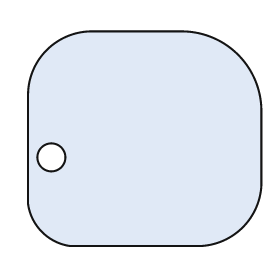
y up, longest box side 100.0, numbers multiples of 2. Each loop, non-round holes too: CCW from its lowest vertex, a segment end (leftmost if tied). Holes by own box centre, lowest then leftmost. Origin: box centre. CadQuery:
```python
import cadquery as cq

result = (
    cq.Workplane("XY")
    .moveTo(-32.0, -46.0)
    .lineTo(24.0, -46.0)
    .threePointArc((42.0, -38.0), (50.0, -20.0))
    .lineTo(50.0, 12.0)
    .threePointArc((40.0, 36.0), (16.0, 46.0))
    .lineTo(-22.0, 46.0)
    .threePointArc((-42.0, 38.0), (-50.0, 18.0))
    .lineTo(-50.0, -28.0)
    .threePointArc((-44.0, -40.0), (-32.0, -46.0))
    .close()
    .moveTo(-40.0, -8.0)
    .circle(6.0)
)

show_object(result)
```